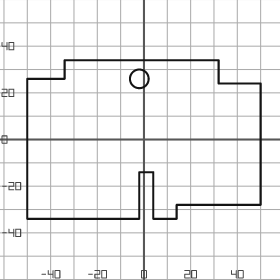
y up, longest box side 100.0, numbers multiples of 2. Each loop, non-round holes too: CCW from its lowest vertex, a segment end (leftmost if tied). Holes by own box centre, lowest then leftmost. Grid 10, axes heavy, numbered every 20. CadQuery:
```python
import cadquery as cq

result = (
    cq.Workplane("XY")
    .moveTo(-50.0, -34.0)
    .lineTo(-2.0, -34.0)
    .lineTo(-2.0, -14.0)
    .lineTo(4.0, -14.0)
    .lineTo(4.0, -34.0)
    .lineTo(14.0, -34.0)
    .lineTo(14.0, -28.0)
    .lineTo(50.0, -28.0)
    .lineTo(50.0, 24.0)
    .lineTo(32.0, 24.0)
    .lineTo(32.0, 34.0)
    .lineTo(-34.0, 34.0)
    .lineTo(-34.0, 26.0)
    .lineTo(-50.0, 26.0)
    .close()
    .moveTo(-2.0, 26.0)
    .circle(4.0)
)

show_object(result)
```